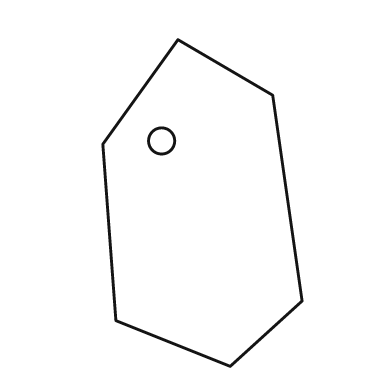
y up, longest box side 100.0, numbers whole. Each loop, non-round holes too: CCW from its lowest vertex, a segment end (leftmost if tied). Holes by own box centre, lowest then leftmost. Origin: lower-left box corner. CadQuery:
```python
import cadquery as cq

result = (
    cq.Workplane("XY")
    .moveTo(39.0, 0.0)
    .lineTo(61.0, 20.0)
    .lineTo(52.0, 83.0)
    .lineTo(23.0, 100.0)
    .lineTo(0.0, 68.0)
    .lineTo(4.0, 14.0)
    .close()
    .moveTo(18.0, 69.0)
    .circle(4.0)
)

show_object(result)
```